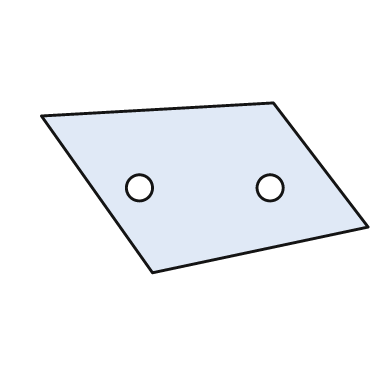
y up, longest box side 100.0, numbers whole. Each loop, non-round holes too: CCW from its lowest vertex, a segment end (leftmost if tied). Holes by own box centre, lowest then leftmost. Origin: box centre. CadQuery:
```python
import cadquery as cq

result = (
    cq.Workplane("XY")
    .moveTo(-16.0, -26.0)
    .lineTo(50.0, -12.0)
    .lineTo(21.0, 26.0)
    .lineTo(-50.0, 22.0)
    .close()
    .moveTo(-20.0, 0.0)
    .circle(4.0)
    .moveTo(20.0, 0.0)
    .circle(4.0)
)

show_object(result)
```